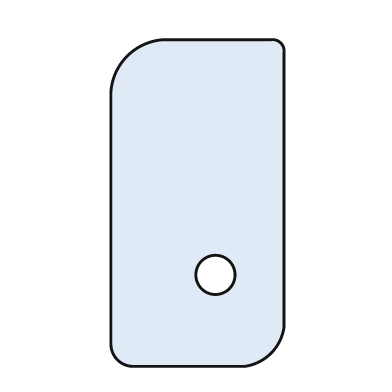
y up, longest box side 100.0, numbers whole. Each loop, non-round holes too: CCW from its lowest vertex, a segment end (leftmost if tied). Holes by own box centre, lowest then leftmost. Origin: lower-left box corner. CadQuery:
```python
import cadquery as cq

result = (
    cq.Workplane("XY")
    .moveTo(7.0, 0.0)
    .lineTo(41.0, 0.0)
    .threePointArc((49.0, 4.0), (53.0, 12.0))
    .lineTo(53.0, 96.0)
    .threePointArc((52.0, 99.0), (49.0, 100.0))
    .lineTo(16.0, 100.0)
    .threePointArc((5.0, 95.0), (0.0, 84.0))
    .lineTo(0.0, 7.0)
    .threePointArc((2.0, 2.0), (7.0, 0.0))
    .close()
    .moveTo(32.0, 28.0)
    .circle(6.0)
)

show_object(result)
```